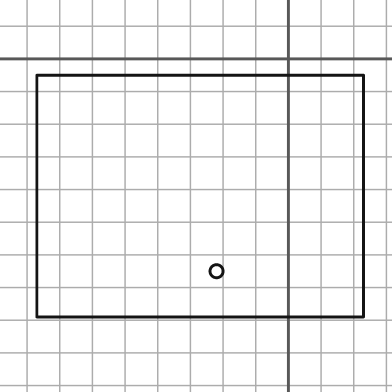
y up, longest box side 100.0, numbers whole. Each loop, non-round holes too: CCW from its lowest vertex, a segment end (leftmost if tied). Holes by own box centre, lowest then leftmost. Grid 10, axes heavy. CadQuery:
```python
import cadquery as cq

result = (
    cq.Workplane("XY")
    .moveTo(-77.0, -79.0)
    .lineTo(23.0, -79.0)
    .lineTo(23.0, -5.0)
    .lineTo(-77.0, -5.0)
    .close()
    .moveTo(-22.0, -65.0)
    .circle(2.0)
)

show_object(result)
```